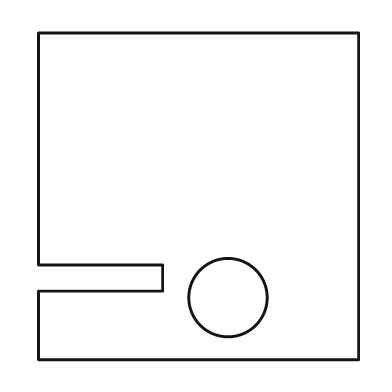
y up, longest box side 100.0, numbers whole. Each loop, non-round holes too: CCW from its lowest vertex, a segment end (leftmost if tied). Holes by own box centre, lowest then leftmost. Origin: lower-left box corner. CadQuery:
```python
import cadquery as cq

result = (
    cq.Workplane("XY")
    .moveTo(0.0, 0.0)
    .lineTo(98.0, 0.0)
    .lineTo(98.0, 100.0)
    .lineTo(0.0, 100.0)
    .lineTo(0.0, 29.0)
    .lineTo(38.0, 29.0)
    .lineTo(38.0, 21.0)
    .lineTo(0.0, 21.0)
    .close()
    .moveTo(58.0, 19.0)
    .circle(12.0)
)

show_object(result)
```